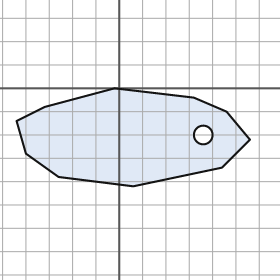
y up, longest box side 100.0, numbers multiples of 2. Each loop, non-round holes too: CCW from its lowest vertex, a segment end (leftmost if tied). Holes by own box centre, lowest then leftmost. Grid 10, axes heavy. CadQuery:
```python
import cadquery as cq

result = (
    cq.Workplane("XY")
    .moveTo(6.0, -42.0)
    .lineTo(44.0, -34.0)
    .lineTo(56.0, -22.0)
    .lineTo(46.0, -10.0)
    .lineTo(32.0, -4.0)
    .lineTo(-2.0, 0.0)
    .lineTo(-32.0, -8.0)
    .lineTo(-44.0, -14.0)
    .lineTo(-40.0, -28.0)
    .lineTo(-26.0, -38.0)
    .close()
    .moveTo(36.0, -20.0)
    .circle(4.0)
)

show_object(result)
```